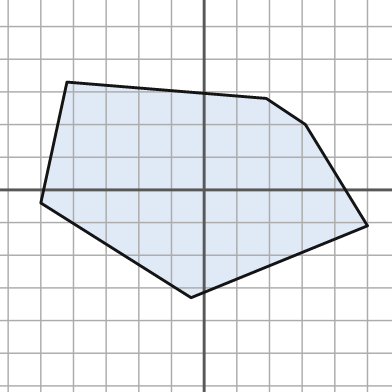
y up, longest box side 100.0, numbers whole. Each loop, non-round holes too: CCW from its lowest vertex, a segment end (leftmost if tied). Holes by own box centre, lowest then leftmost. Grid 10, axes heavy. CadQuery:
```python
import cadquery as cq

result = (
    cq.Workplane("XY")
    .moveTo(-4.0, -33.0)
    .lineTo(50.0, -11.0)
    .lineTo(31.0, 20.0)
    .lineTo(19.0, 28.0)
    .lineTo(-42.0, 33.0)
    .lineTo(-50.0, -4.0)
    .close()
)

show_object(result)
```